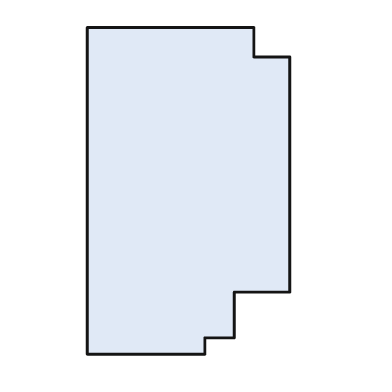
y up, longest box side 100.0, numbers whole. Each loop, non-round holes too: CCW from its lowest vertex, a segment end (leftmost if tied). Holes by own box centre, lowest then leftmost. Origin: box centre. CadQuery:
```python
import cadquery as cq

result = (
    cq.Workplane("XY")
    .moveTo(-31.0, -50.0)
    .lineTo(5.0, -50.0)
    .lineTo(5.0, -45.0)
    .lineTo(14.0, -45.0)
    .lineTo(14.0, -31.0)
    .lineTo(31.0, -31.0)
    .lineTo(31.0, 41.0)
    .lineTo(20.0, 41.0)
    .lineTo(20.0, 50.0)
    .lineTo(-31.0, 50.0)
    .close()
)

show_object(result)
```